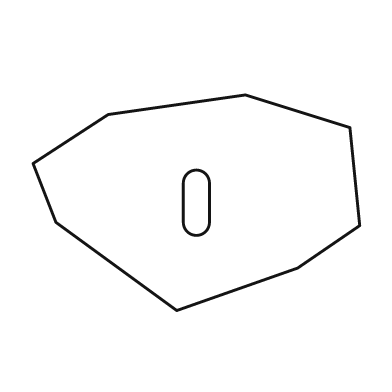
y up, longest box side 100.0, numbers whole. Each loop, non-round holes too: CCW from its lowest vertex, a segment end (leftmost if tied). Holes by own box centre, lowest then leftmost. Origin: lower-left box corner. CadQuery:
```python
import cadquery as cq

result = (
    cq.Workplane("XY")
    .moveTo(44.0, 0.0)
    .lineTo(81.0, 13.0)
    .lineTo(100.0, 26.0)
    .lineTo(97.0, 56.0)
    .lineTo(65.0, 66.0)
    .lineTo(23.0, 60.0)
    .lineTo(0.0, 45.0)
    .lineTo(7.0, 27.0)
    .close()
    .moveTo(46.0, 27.0)
    .threePointArc((50.0, 23.0), (54.0, 27.0))
    .lineTo(54.0, 39.0)
    .threePointArc((50.0, 43.0), (46.0, 39.0))
    .close()
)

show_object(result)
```